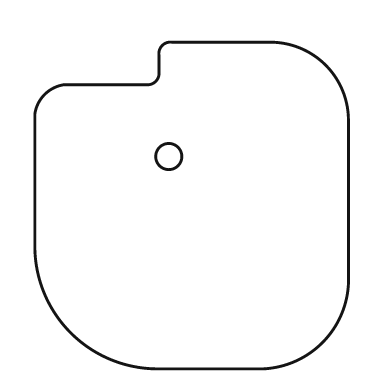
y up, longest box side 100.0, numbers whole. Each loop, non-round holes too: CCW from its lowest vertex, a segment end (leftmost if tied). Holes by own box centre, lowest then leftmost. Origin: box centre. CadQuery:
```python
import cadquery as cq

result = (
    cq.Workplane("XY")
    .moveTo(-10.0, -50.0)
    .lineTo(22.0, -50.0)
    .threePointArc((40.0, -42.0), (48.0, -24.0))
    .lineTo(48.0, 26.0)
    .threePointArc((41.0, 43.0), (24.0, 50.0))
    .lineTo(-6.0, 50.0)
    .threePointArc((-9.0, 49.0), (-10.0, 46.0))
    .lineTo(-10.0, 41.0)
    .threePointArc((-11.0, 38.0), (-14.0, 37.0))
    .lineTo(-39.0, 37.0)
    .threePointArc((-45.0, 34.0), (-48.0, 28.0))
    .lineTo(-48.0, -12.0)
    .threePointArc((-37.0, -39.0), (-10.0, -50.0))
    .close()
    .moveTo(-7.0, 15.0)
    .circle(4.0)
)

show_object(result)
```